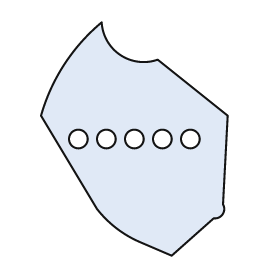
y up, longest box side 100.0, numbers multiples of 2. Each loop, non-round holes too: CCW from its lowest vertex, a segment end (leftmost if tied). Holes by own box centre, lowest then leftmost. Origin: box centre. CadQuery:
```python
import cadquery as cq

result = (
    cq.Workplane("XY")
    .moveTo(16.0, -50.0)
    .lineTo(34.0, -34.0)
    .threePointArc((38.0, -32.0), (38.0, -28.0))
    .lineTo(40.0, 10.0)
    .lineTo(10.0, 34.0)
    .threePointArc((-6.0, 36.0), (-14.0, 50.0))
    .threePointArc((-30.0, 32.0), (-40.0, 10.0))
    .lineTo(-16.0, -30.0)
    .threePointArc((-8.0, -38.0), (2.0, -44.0))
    .close()
    .moveTo(-24.0, 0.0)
    .circle(4.0)
    .moveTo(-12.0, 0.0)
    .circle(4.0)
    .moveTo(0.0, 0.0)
    .circle(4.0)
    .moveTo(12.0, 0.0)
    .circle(4.0)
    .moveTo(24.0, 0.0)
    .circle(4.0)
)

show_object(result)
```